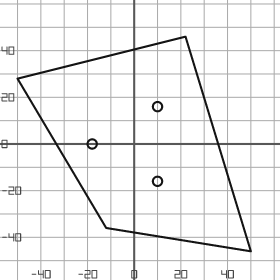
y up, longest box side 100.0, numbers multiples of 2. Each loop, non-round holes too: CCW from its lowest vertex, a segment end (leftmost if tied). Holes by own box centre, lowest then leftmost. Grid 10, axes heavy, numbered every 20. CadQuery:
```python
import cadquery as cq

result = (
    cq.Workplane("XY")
    .moveTo(50.0, -46.0)
    .lineTo(22.0, 46.0)
    .lineTo(-50.0, 28.0)
    .lineTo(-12.0, -36.0)
    .close()
    .moveTo(10.0, -16.0)
    .circle(2.0)
    .moveTo(-18.0, 0.0)
    .circle(2.0)
    .moveTo(10.0, 16.0)
    .circle(2.0)
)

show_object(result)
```